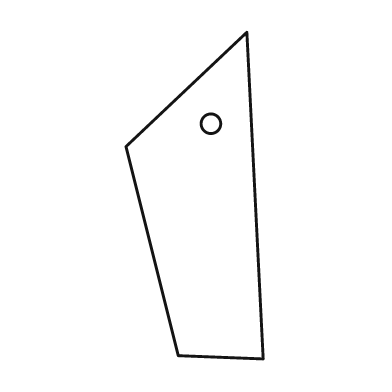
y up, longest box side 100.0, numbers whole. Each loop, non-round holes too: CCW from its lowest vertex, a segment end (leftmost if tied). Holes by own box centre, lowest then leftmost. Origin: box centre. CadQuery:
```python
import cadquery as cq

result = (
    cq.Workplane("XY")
    .moveTo(21.0, -50.0)
    .lineTo(16.0, 50.0)
    .lineTo(-21.0, 15.0)
    .lineTo(-5.0, -49.0)
    .close()
    .moveTo(5.0, 22.0)
    .circle(3.0)
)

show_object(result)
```